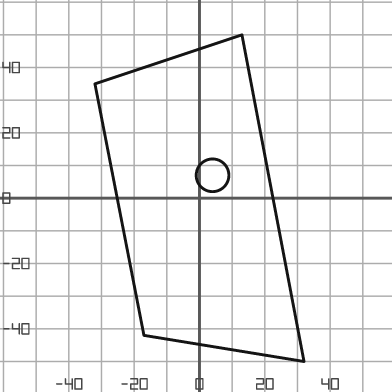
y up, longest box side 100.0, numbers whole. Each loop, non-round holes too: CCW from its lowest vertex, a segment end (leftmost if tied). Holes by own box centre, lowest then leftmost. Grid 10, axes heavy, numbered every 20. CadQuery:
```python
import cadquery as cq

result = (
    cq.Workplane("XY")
    .moveTo(32.0, -50.0)
    .lineTo(13.0, 50.0)
    .lineTo(-32.0, 35.0)
    .lineTo(-17.0, -42.0)
    .close()
    .moveTo(4.0, 7.0)
    .circle(5.0)
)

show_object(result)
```